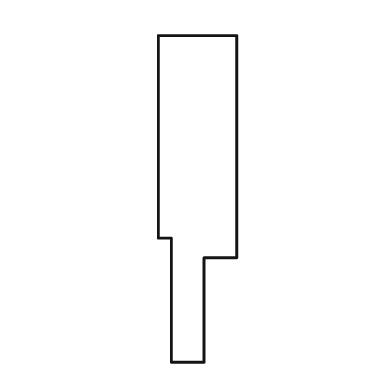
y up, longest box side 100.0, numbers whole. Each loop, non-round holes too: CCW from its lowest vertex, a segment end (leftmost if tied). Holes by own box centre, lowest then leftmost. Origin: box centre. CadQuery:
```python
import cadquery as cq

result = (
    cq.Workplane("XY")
    .moveTo(-8.0, -50.0)
    .lineTo(2.0, -50.0)
    .lineTo(2.0, -18.0)
    .lineTo(12.0, -18.0)
    .lineTo(12.0, 50.0)
    .lineTo(-12.0, 50.0)
    .lineTo(-12.0, -12.0)
    .lineTo(-8.0, -12.0)
    .close()
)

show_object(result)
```